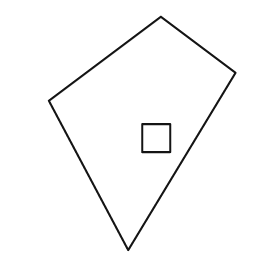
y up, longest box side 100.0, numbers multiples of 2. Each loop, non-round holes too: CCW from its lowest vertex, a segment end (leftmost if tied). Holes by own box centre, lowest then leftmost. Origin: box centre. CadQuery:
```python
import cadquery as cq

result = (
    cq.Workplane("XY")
    .moveTo(-6.0, -50.0)
    .lineTo(40.0, 26.0)
    .lineTo(8.0, 50.0)
    .lineTo(-40.0, 14.0)
    .close()
    .moveTo(0.0, -8.0)
    .lineTo(12.0, -8.0)
    .lineTo(12.0, 4.0)
    .lineTo(0.0, 4.0)
    .close()
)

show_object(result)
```